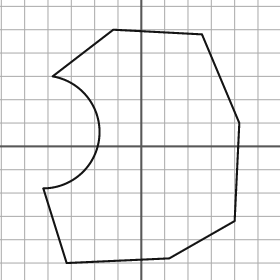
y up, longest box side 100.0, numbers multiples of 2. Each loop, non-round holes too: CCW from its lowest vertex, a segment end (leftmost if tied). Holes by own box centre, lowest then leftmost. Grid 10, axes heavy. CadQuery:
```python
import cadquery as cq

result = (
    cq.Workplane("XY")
    .moveTo(-32.0, -50.0)
    .lineTo(12.0, -48.0)
    .lineTo(40.0, -32.0)
    .lineTo(42.0, 10.0)
    .lineTo(26.0, 48.0)
    .lineTo(-12.0, 50.0)
    .lineTo(-38.0, 30.0)
    .threePointArc((-18.0, 4.0), (-42.0, -18.0))
    .close()
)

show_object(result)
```